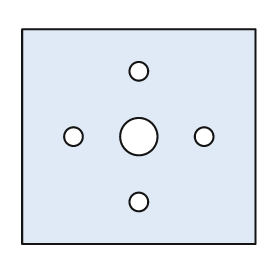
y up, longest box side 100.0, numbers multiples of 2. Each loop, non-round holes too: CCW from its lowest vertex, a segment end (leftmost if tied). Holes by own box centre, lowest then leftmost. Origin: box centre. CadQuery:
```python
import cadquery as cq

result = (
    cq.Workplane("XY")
    .moveTo(-50.0, -46.0)
    .lineTo(50.0, -46.0)
    .lineTo(50.0, 46.0)
    .lineTo(-50.0, 46.0)
    .close()
    .moveTo(0.0, -28.0)
    .circle(4.0)
    .moveTo(-28.0, 0.0)
    .circle(4.0)
    .moveTo(0.0, 0.0)
    .circle(8.0)
    .moveTo(28.0, 0.0)
    .circle(4.0)
    .moveTo(0.0, 28.0)
    .circle(4.0)
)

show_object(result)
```